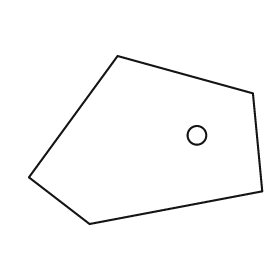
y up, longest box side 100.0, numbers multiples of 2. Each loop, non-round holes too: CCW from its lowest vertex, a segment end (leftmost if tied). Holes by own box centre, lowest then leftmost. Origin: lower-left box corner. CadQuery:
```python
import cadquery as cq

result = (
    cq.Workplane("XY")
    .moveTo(26.0, 0.0)
    .lineTo(100.0, 14.0)
    .lineTo(96.0, 56.0)
    .lineTo(38.0, 72.0)
    .lineTo(0.0, 20.0)
    .close()
    .moveTo(72.0, 38.0)
    .circle(4.0)
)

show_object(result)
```